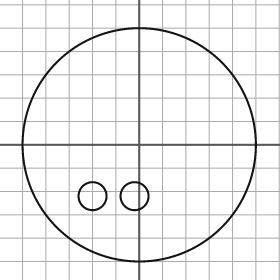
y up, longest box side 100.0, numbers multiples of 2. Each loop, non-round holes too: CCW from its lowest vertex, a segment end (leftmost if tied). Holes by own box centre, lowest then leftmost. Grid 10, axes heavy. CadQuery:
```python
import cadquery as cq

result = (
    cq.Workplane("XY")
    .moveTo(0.0, 0.0)
    .circle(50.0)
    .moveTo(-20.0, -22.0)
    .circle(6.0)
    .moveTo(-2.0, -22.0)
    .circle(6.0)
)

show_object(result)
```